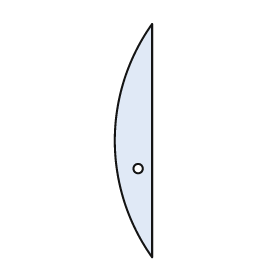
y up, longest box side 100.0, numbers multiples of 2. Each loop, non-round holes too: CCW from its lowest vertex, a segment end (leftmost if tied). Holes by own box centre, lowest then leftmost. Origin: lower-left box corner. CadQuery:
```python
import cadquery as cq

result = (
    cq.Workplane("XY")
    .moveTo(16.0, 0.0)
    .lineTo(16.0, 100.0)
    .threePointArc((0.0, 50.0), (16.0, 0.0))
    .close()
    .moveTo(10.0, 38.0)
    .circle(2.0)
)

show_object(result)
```